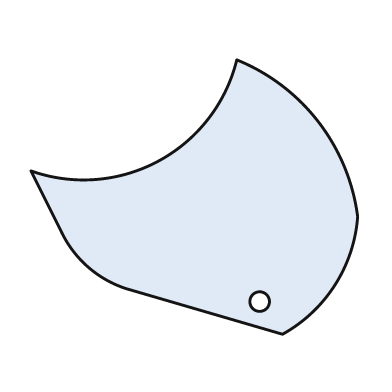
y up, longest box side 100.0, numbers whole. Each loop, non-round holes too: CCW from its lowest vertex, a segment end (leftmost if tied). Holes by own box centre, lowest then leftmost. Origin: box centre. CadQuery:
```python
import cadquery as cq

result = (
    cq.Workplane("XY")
    .moveTo(27.0, -42.0)
    .threePointArc((43.0, -27.0), (50.0, -6.0))
    .threePointArc((38.0, 23.0), (13.0, 42.0))
    .threePointArc((-11.0, 11.0), (-50.0, 8.0))
    .lineTo(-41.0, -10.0)
    .threePointArc((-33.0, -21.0), (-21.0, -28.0))
    .close()
    .moveTo(20.0, -32.0)
    .circle(3.0)
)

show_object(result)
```